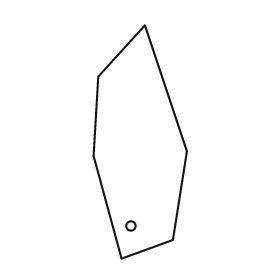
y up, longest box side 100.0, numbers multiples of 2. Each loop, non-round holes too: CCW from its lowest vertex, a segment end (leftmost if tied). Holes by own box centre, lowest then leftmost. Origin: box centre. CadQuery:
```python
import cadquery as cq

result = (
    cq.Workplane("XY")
    .moveTo(-8.0, -50.0)
    .lineTo(14.0, -42.0)
    .lineTo(20.0, -4.0)
    .lineTo(2.0, 50.0)
    .lineTo(-18.0, 28.0)
    .lineTo(-20.0, -6.0)
    .close()
    .moveTo(-4.0, -36.0)
    .circle(2.0)
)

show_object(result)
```